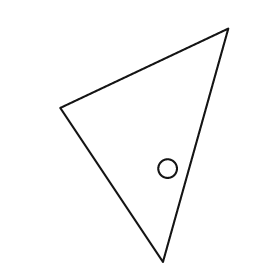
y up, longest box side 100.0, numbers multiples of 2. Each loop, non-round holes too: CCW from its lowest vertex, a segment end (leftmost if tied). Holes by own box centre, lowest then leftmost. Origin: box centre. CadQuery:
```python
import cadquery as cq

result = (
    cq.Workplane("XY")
    .moveTo(8.0, -50.0)
    .lineTo(36.0, 50.0)
    .lineTo(-36.0, 16.0)
    .close()
    .moveTo(10.0, -10.0)
    .circle(4.0)
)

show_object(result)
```